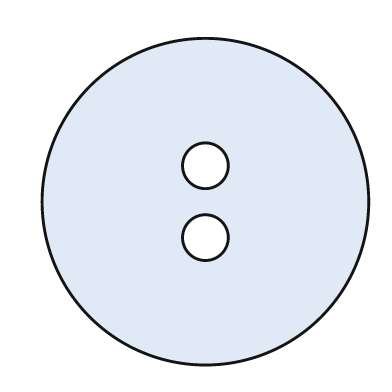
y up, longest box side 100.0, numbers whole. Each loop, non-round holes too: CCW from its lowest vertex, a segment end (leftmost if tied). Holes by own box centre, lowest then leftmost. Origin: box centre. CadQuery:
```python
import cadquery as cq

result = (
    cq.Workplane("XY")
    .moveTo(0.0, 0.0)
    .circle(50.0)
    .moveTo(0.0, -11.0)
    .circle(7.0)
    .moveTo(0.0, 11.0)
    .circle(7.0)
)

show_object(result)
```